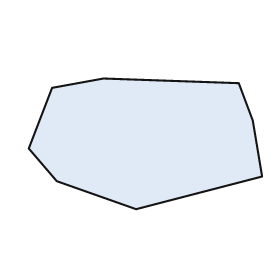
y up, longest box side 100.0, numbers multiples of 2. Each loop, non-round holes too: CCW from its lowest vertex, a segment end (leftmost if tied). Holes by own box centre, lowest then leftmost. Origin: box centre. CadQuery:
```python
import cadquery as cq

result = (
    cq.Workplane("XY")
    .moveTo(-4.0, -28.0)
    .lineTo(50.0, -14.0)
    .lineTo(46.0, 10.0)
    .lineTo(40.0, 26.0)
    .lineTo(-18.0, 28.0)
    .lineTo(-40.0, 24.0)
    .lineTo(-50.0, -2.0)
    .lineTo(-38.0, -16.0)
    .close()
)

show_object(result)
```